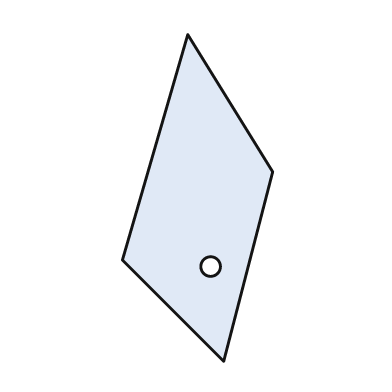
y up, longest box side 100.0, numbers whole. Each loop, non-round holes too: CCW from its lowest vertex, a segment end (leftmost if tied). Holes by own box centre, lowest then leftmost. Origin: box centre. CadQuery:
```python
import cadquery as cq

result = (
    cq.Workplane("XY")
    .moveTo(8.0, -50.0)
    .lineTo(23.0, 8.0)
    .lineTo(-3.0, 50.0)
    .lineTo(-23.0, -19.0)
    .close()
    .moveTo(4.0, -21.0)
    .circle(3.0)
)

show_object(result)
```